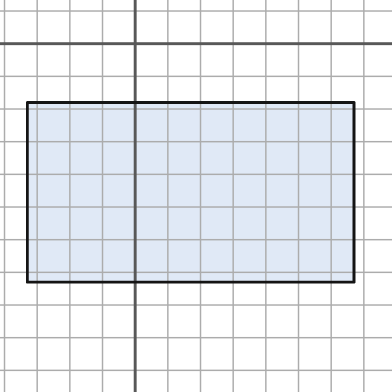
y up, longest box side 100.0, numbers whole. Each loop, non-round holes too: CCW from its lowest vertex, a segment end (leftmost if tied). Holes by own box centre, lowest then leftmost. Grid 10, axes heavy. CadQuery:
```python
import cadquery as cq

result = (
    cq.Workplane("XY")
    .moveTo(-33.0, -73.0)
    .lineTo(67.0, -73.0)
    .lineTo(67.0, -18.0)
    .lineTo(-33.0, -18.0)
    .close()
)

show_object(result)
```